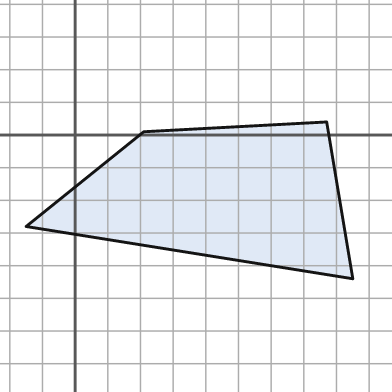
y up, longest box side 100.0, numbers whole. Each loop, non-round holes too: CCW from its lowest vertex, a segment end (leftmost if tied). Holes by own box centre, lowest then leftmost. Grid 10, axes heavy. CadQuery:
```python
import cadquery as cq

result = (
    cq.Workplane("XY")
    .moveTo(85.0, -44.0)
    .lineTo(77.0, 4.0)
    .lineTo(21.0, 1.0)
    .lineTo(-15.0, -28.0)
    .close()
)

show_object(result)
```